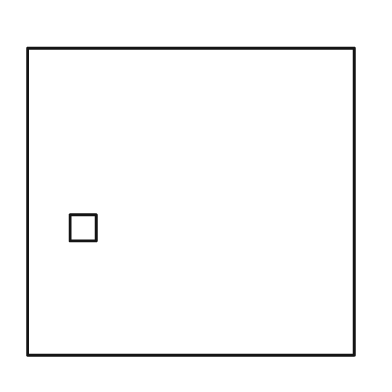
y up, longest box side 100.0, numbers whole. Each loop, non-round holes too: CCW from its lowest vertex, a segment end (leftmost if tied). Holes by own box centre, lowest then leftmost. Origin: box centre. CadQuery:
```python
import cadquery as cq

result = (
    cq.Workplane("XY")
    .moveTo(-50.0, -47.0)
    .lineTo(50.0, -47.0)
    .lineTo(50.0, 47.0)
    .lineTo(-50.0, 47.0)
    .close()
    .moveTo(-37.0, -12.0)
    .lineTo(-29.0, -12.0)
    .lineTo(-29.0, -4.0)
    .lineTo(-37.0, -4.0)
    .close()
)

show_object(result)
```